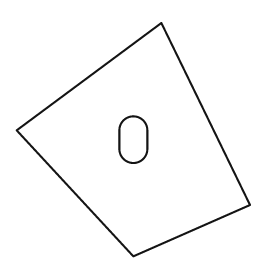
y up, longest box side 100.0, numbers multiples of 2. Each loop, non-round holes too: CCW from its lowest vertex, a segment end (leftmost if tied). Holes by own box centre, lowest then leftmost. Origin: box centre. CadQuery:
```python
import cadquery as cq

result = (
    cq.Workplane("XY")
    .moveTo(0.0, -50.0)
    .lineTo(50.0, -28.0)
    .lineTo(12.0, 50.0)
    .lineTo(-50.0, 4.0)
    .close()
    .moveTo(-6.0, -4.0)
    .threePointArc((0.0, -10.0), (6.0, -4.0))
    .lineTo(6.0, 4.0)
    .threePointArc((0.0, 10.0), (-6.0, 4.0))
    .close()
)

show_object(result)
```